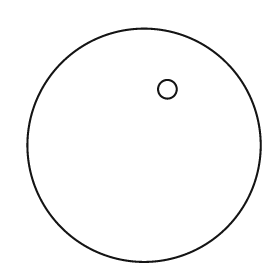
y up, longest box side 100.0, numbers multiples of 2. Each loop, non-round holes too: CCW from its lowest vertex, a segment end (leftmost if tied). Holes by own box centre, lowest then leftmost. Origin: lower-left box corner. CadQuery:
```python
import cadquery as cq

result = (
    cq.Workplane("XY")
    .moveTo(50.0, 50.0)
    .circle(50.0)
    .moveTo(60.0, 74.0)
    .circle(4.0)
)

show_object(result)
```